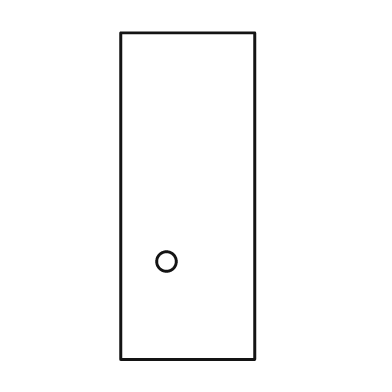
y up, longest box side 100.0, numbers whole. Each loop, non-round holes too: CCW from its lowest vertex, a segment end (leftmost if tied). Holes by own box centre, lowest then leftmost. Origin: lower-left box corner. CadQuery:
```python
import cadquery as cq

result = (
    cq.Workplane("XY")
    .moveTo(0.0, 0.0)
    .lineTo(41.0, 0.0)
    .lineTo(41.0, 100.0)
    .lineTo(0.0, 100.0)
    .close()
    .moveTo(14.0, 30.0)
    .circle(3.0)
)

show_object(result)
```